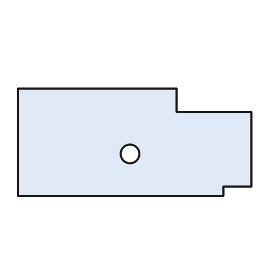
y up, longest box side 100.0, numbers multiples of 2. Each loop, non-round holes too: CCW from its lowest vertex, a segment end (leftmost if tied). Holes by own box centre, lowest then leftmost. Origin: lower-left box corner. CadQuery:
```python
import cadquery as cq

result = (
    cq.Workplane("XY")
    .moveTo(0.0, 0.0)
    .lineTo(88.0, 0.0)
    .lineTo(88.0, 4.0)
    .lineTo(100.0, 4.0)
    .lineTo(100.0, 36.0)
    .lineTo(68.0, 36.0)
    .lineTo(68.0, 46.0)
    .lineTo(0.0, 46.0)
    .close()
    .moveTo(48.0, 18.0)
    .circle(4.0)
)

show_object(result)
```